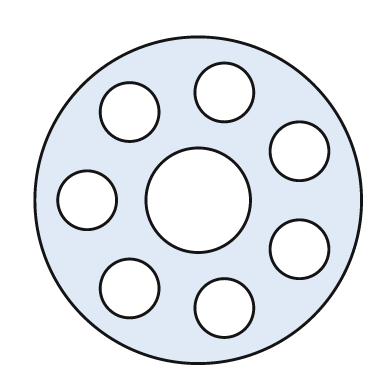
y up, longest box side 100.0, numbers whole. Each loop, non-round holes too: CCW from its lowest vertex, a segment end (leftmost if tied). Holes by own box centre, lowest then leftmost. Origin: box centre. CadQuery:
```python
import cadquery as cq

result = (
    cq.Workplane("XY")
    .moveTo(0.0, 0.0)
    .circle(50.0)
    .moveTo(8.0, -33.0)
    .circle(9.0)
    .moveTo(-21.0, -27.0)
    .circle(9.0)
    .moveTo(31.0, -15.0)
    .circle(9.0)
    .moveTo(-34.0, 0.0)
    .circle(9.0)
    .moveTo(0.0, 0.0)
    .circle(16.0)
    .moveTo(31.0, 15.0)
    .circle(9.0)
    .moveTo(-21.0, 27.0)
    .circle(9.0)
    .moveTo(8.0, 33.0)
    .circle(9.0)
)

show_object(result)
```